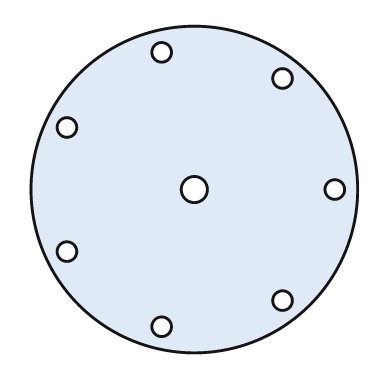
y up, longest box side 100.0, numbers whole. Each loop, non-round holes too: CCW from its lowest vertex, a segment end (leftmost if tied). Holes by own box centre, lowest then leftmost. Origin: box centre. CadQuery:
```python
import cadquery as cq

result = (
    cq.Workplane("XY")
    .moveTo(0.0, 0.0)
    .circle(50.0)
    .moveTo(-10.0, -42.0)
    .circle(3.0)
    .moveTo(27.0, -34.0)
    .circle(3.0)
    .moveTo(-39.0, -19.0)
    .circle(3.0)
    .moveTo(0.0, 0.0)
    .circle(4.0)
    .moveTo(43.0, 0.0)
    .circle(3.0)
    .moveTo(-39.0, 19.0)
    .circle(3.0)
    .moveTo(27.0, 34.0)
    .circle(3.0)
    .moveTo(-10.0, 42.0)
    .circle(3.0)
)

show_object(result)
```